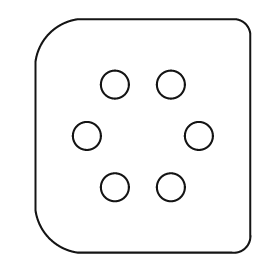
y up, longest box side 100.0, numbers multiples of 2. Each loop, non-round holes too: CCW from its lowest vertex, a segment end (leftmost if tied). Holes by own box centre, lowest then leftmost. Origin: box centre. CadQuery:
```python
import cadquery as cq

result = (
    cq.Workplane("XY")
    .moveTo(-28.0, -50.0)
    .lineTo(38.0, -50.0)
    .threePointArc((44.0, -48.0), (46.0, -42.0))
    .lineTo(46.0, 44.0)
    .threePointArc((44.0, 48.0), (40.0, 50.0))
    .lineTo(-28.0, 50.0)
    .threePointArc((-40.0, 44.0), (-46.0, 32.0))
    .lineTo(-46.0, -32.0)
    .threePointArc((-40.0, -44.0), (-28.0, -50.0))
    .close()
    .moveTo(-12.0, -22.0)
    .circle(6.0)
    .moveTo(12.0, -22.0)
    .circle(6.0)
    .moveTo(-24.0, 0.0)
    .circle(6.0)
    .moveTo(24.0, 0.0)
    .circle(6.0)
    .moveTo(-12.0, 22.0)
    .circle(6.0)
    .moveTo(12.0, 22.0)
    .circle(6.0)
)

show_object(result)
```